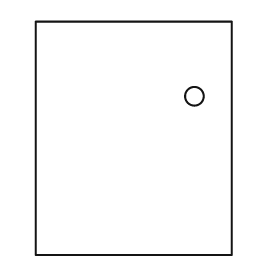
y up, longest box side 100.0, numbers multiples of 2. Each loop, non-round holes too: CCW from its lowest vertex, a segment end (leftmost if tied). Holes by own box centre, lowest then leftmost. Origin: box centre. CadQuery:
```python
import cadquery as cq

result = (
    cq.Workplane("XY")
    .moveTo(-42.0, -50.0)
    .lineTo(42.0, -50.0)
    .lineTo(42.0, 50.0)
    .lineTo(-42.0, 50.0)
    .close()
    .moveTo(26.0, 18.0)
    .circle(4.0)
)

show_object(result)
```